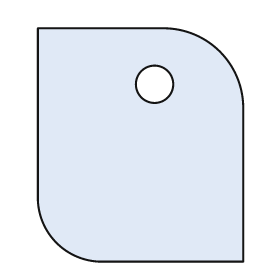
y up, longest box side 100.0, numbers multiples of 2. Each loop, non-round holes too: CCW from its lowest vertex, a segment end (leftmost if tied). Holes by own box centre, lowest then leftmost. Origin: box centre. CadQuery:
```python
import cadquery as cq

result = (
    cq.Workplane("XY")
    .moveTo(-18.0, -50.0)
    .lineTo(44.0, -50.0)
    .lineTo(44.0, 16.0)
    .threePointArc((34.0, 40.0), (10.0, 50.0))
    .lineTo(-44.0, 50.0)
    .lineTo(-44.0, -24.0)
    .threePointArc((-36.0, -42.0), (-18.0, -50.0))
    .close()
    .moveTo(6.0, 26.0)
    .circle(8.0)
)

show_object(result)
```